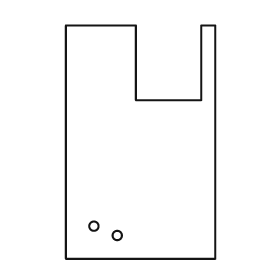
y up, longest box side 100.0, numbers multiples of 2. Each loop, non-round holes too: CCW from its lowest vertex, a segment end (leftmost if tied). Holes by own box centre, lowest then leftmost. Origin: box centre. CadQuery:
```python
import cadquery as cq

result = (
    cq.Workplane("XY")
    .moveTo(-32.0, -50.0)
    .lineTo(32.0, -50.0)
    .lineTo(32.0, 50.0)
    .lineTo(26.0, 50.0)
    .lineTo(26.0, 18.0)
    .lineTo(-2.0, 18.0)
    .lineTo(-2.0, 50.0)
    .lineTo(-32.0, 50.0)
    .close()
    .moveTo(-10.0, -40.0)
    .circle(2.0)
    .moveTo(-20.0, -36.0)
    .circle(2.0)
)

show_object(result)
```